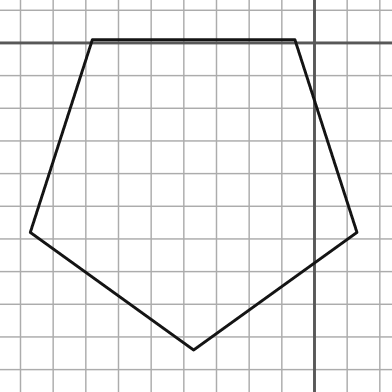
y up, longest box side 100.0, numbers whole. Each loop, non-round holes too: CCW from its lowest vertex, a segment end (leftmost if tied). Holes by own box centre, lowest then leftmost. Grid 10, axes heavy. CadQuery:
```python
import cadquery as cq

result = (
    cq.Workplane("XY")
    .moveTo(-37.0, -94.0)
    .lineTo(13.0, -58.0)
    .lineTo(-6.0, 1.0)
    .lineTo(-68.0, 1.0)
    .lineTo(-87.0, -58.0)
    .close()
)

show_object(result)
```